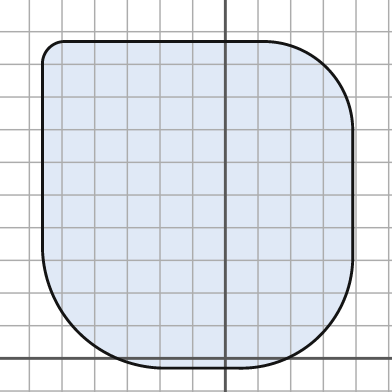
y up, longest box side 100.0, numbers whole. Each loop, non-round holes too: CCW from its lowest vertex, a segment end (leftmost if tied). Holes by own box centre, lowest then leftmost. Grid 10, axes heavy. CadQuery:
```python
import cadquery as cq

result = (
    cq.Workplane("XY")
    .moveTo(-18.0, -3.0)
    .lineTo(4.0, -3.0)
    .threePointArc((29.0, 7.0), (39.0, 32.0))
    .lineTo(39.0, 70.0)
    .threePointArc((31.0, 89.0), (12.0, 97.0))
    .lineTo(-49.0, 97.0)
    .threePointArc((-54.0, 95.0), (-56.0, 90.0))
    .lineTo(-56.0, 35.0)
    .threePointArc((-45.0, 8.0), (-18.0, -3.0))
    .close()
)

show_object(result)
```